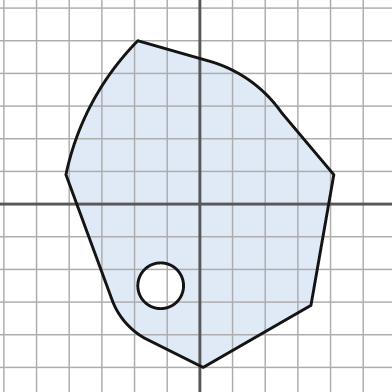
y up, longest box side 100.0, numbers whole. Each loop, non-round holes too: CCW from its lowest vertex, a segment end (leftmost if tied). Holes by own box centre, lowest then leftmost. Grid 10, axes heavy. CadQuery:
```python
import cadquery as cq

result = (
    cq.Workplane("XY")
    .moveTo(1.0, -50.0)
    .lineTo(34.0, -31.0)
    .lineTo(41.0, 9.0)
    .lineTo(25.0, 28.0)
    .threePointArc((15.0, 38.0), (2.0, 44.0))
    .lineTo(-19.0, 50.0)
    .threePointArc((-33.0, 31.0), (-41.0, 9.0))
    .lineTo(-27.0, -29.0)
    .threePointArc((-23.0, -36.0), (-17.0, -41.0))
    .close()
    .moveTo(-12.0, -25.0)
    .circle(7.0)
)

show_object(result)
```